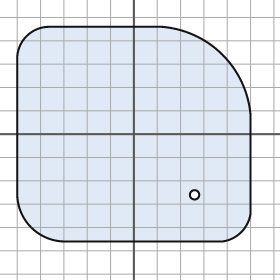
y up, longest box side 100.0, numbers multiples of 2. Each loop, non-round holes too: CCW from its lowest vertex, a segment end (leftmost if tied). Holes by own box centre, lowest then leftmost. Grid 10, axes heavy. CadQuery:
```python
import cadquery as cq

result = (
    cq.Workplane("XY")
    .moveTo(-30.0, -46.0)
    .lineTo(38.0, -46.0)
    .threePointArc((46.0, -42.0), (50.0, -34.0))
    .lineTo(50.0, 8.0)
    .threePointArc((38.0, 34.0), (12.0, 46.0))
    .lineTo(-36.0, 46.0)
    .threePointArc((-46.0, 42.0), (-50.0, 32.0))
    .lineTo(-50.0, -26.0)
    .threePointArc((-44.0, -40.0), (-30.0, -46.0))
    .close()
    .moveTo(26.0, -26.0)
    .circle(2.0)
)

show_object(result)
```